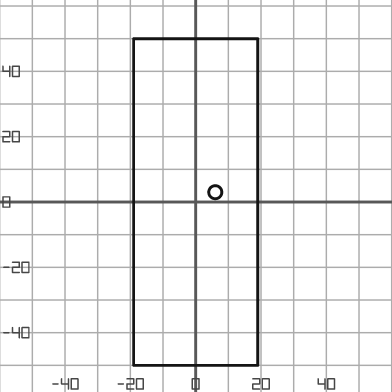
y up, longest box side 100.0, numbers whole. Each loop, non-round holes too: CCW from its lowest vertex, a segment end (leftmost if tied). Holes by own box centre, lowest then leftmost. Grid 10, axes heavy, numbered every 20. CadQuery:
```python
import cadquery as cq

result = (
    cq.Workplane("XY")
    .moveTo(-19.0, -50.0)
    .lineTo(19.0, -50.0)
    .lineTo(19.0, 50.0)
    .lineTo(-19.0, 50.0)
    .close()
    .moveTo(6.0, 3.0)
    .circle(2.0)
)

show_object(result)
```